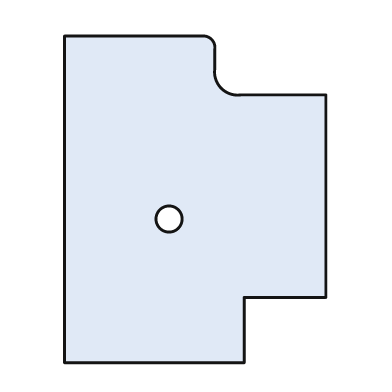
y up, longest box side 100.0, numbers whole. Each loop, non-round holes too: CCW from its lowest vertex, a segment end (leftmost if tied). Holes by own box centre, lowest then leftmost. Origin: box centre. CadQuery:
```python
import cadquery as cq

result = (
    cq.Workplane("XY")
    .moveTo(-40.0, -50.0)
    .lineTo(15.0, -50.0)
    .lineTo(15.0, -30.0)
    .lineTo(40.0, -30.0)
    .lineTo(40.0, 32.0)
    .lineTo(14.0, 32.0)
    .threePointArc((8.0, 34.0), (6.0, 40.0))
    .lineTo(6.0, 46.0)
    .threePointArc((5.0, 49.0), (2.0, 50.0))
    .lineTo(-40.0, 50.0)
    .close()
    .moveTo(-8.0, -6.0)
    .circle(4.0)
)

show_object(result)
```